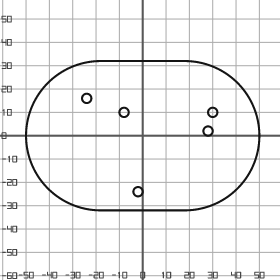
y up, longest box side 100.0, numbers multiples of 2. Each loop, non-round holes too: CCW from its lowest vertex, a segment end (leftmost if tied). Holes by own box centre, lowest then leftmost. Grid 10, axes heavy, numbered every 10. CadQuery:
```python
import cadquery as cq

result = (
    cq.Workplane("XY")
    .moveTo(-18.0, -32.0)
    .lineTo(18.0, -32.0)
    .threePointArc((50.0, 0.0), (18.0, 32.0))
    .lineTo(-18.0, 32.0)
    .threePointArc((-50.0, 0.0), (-18.0, -32.0))
    .close()
    .moveTo(-2.0, -24.0)
    .circle(2.0)
    .moveTo(28.0, 2.0)
    .circle(2.0)
    .moveTo(-8.0, 10.0)
    .circle(2.0)
    .moveTo(30.0, 10.0)
    .circle(2.0)
    .moveTo(-24.0, 16.0)
    .circle(2.0)
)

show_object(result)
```